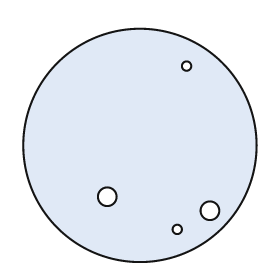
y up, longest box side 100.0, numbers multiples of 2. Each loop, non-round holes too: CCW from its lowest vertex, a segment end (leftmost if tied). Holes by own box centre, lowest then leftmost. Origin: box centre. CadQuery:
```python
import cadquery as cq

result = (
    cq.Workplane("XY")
    .moveTo(0.0, 0.0)
    .circle(50.0)
    .moveTo(16.0, -36.0)
    .circle(2.0)
    .moveTo(30.0, -28.0)
    .circle(4.0)
    .moveTo(-14.0, -22.0)
    .circle(4.0)
    .moveTo(20.0, 34.0)
    .circle(2.0)
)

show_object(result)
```